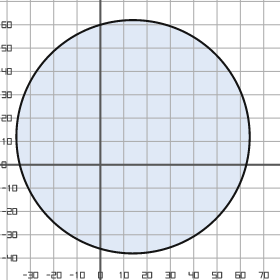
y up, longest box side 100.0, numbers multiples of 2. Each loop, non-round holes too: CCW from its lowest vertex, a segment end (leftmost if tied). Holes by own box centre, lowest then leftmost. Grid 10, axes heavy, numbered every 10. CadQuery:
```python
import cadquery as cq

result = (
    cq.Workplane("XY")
    .moveTo(14.0, 12.0)
    .circle(50.0)
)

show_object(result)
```